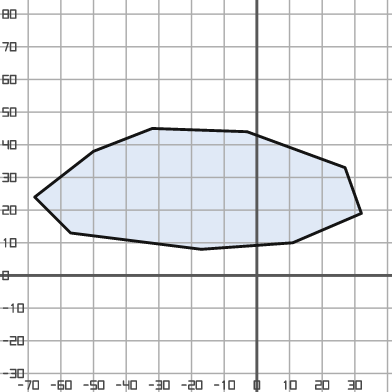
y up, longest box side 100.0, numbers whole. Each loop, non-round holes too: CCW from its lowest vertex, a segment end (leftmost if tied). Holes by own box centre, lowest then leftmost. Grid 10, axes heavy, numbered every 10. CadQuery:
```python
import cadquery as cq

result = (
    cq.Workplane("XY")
    .moveTo(-17.0, 8.0)
    .lineTo(11.0, 10.0)
    .lineTo(32.0, 19.0)
    .lineTo(27.0, 33.0)
    .lineTo(-3.0, 44.0)
    .lineTo(-32.0, 45.0)
    .lineTo(-50.0, 38.0)
    .lineTo(-68.0, 24.0)
    .lineTo(-57.0, 13.0)
    .close()
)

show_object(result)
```